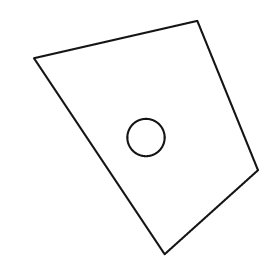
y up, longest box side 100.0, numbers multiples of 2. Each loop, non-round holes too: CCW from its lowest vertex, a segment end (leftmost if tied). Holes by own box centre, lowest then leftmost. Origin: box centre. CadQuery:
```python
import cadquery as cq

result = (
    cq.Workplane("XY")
    .moveTo(8.0, -50.0)
    .lineTo(48.0, -14.0)
    .lineTo(22.0, 50.0)
    .lineTo(-48.0, 34.0)
    .close()
    .moveTo(0.0, 0.0)
    .circle(8.0)
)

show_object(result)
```